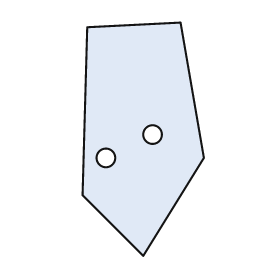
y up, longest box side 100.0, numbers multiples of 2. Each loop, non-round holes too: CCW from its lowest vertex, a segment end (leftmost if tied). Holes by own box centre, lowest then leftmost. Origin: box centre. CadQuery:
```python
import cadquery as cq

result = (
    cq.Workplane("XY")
    .moveTo(0.0, -50.0)
    .lineTo(26.0, -8.0)
    .lineTo(16.0, 50.0)
    .lineTo(-24.0, 48.0)
    .lineTo(-26.0, -24.0)
    .close()
    .moveTo(-16.0, -8.0)
    .circle(4.0)
    .moveTo(4.0, 2.0)
    .circle(4.0)
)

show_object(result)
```